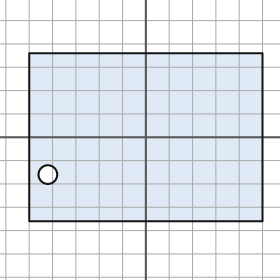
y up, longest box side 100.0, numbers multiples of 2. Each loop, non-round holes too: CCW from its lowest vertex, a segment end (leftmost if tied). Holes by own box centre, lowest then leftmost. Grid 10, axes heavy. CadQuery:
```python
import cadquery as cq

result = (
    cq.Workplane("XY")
    .moveTo(-50.0, -36.0)
    .lineTo(50.0, -36.0)
    .lineTo(50.0, 36.0)
    .lineTo(-50.0, 36.0)
    .close()
    .moveTo(-42.0, -16.0)
    .circle(4.0)
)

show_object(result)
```